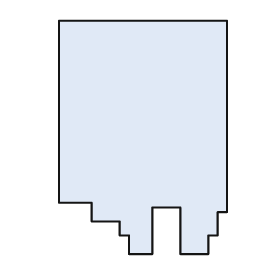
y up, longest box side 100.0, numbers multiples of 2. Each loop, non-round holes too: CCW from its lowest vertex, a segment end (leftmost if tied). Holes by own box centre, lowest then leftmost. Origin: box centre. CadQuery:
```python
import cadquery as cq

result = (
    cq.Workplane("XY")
    .moveTo(-6.0, -50.0)
    .lineTo(4.0, -50.0)
    .lineTo(4.0, -30.0)
    .lineTo(16.0, -30.0)
    .lineTo(16.0, -50.0)
    .lineTo(28.0, -50.0)
    .lineTo(28.0, -42.0)
    .lineTo(32.0, -42.0)
    .lineTo(32.0, -32.0)
    .lineTo(36.0, -32.0)
    .lineTo(36.0, 50.0)
    .lineTo(-36.0, 50.0)
    .lineTo(-36.0, -28.0)
    .lineTo(-22.0, -28.0)
    .lineTo(-22.0, -36.0)
    .lineTo(-10.0, -36.0)
    .lineTo(-10.0, -42.0)
    .lineTo(-6.0, -42.0)
    .close()
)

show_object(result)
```